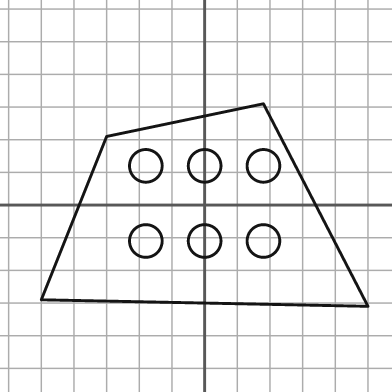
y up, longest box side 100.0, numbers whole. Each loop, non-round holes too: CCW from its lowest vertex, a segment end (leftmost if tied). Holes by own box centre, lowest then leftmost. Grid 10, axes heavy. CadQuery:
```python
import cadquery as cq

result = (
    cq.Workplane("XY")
    .moveTo(50.0, -31.0)
    .lineTo(18.0, 31.0)
    .lineTo(-30.0, 21.0)
    .lineTo(-50.0, -29.0)
    .close()
    .moveTo(-18.0, -11.0)
    .circle(5.0)
    .moveTo(0.0, -11.0)
    .circle(5.0)
    .moveTo(18.0, -11.0)
    .circle(5.0)
    .moveTo(-18.0, 12.0)
    .circle(5.0)
    .moveTo(0.0, 12.0)
    .circle(5.0)
    .moveTo(18.0, 12.0)
    .circle(5.0)
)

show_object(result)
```